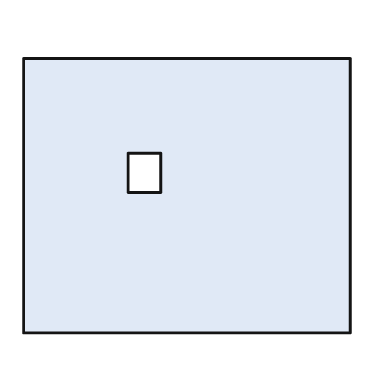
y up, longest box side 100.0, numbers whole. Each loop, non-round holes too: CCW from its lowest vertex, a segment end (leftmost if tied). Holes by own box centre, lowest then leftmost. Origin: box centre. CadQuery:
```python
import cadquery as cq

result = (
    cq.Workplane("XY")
    .moveTo(-50.0, -42.0)
    .lineTo(50.0, -42.0)
    .lineTo(50.0, 42.0)
    .lineTo(-50.0, 42.0)
    .close()
    .moveTo(-18.0, 1.0)
    .lineTo(-8.0, 1.0)
    .lineTo(-8.0, 13.0)
    .lineTo(-18.0, 13.0)
    .close()
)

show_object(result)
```